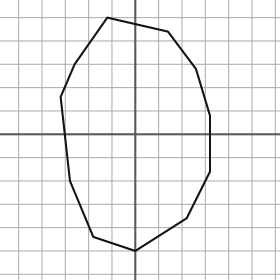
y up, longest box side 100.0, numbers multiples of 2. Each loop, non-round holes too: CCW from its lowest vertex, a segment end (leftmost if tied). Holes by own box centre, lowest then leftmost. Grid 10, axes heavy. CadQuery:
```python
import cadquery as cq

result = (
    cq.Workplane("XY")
    .moveTo(0.0, -50.0)
    .lineTo(22.0, -36.0)
    .lineTo(32.0, -16.0)
    .lineTo(32.0, 8.0)
    .lineTo(26.0, 28.0)
    .lineTo(14.0, 44.0)
    .lineTo(-12.0, 50.0)
    .lineTo(-26.0, 30.0)
    .lineTo(-32.0, 16.0)
    .lineTo(-28.0, -20.0)
    .lineTo(-18.0, -44.0)
    .close()
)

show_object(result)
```